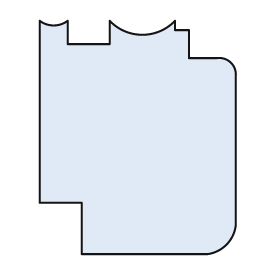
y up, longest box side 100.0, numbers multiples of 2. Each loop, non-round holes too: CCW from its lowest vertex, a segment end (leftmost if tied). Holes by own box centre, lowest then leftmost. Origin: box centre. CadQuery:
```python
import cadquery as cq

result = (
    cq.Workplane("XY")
    .moveTo(-24.0, -50.0)
    .lineTo(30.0, -50.0)
    .threePointArc((38.0, -46.0), (42.0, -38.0))
    .lineTo(42.0, 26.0)
    .threePointArc((40.0, 32.0), (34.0, 34.0))
    .lineTo(22.0, 34.0)
    .lineTo(22.0, 46.0)
    .lineTo(16.0, 46.0)
    .lineTo(16.0, 50.0)
    .threePointArc((2.0, 44.0), (-12.0, 50.0))
    .lineTo(-12.0, 40.0)
    .lineTo(-30.0, 40.0)
    .lineTo(-30.0, 50.0)
    .threePointArc((-36.0, 48.0), (-42.0, 50.0))
    .lineTo(-42.0, -28.0)
    .lineTo(-24.0, -28.0)
    .close()
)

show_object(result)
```